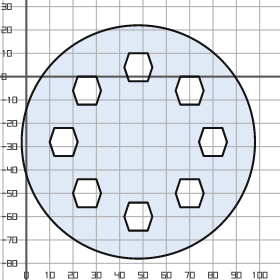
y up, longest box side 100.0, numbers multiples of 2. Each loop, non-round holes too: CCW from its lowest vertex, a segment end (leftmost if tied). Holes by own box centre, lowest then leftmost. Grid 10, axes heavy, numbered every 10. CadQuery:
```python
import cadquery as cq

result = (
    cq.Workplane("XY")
    .moveTo(48.0, -28.0)
    .circle(50.0)
    .moveTo(44.0, -66.0)
    .lineTo(52.0, -66.0)
    .lineTo(54.0, -60.0)
    .lineTo(52.0, -54.0)
    .lineTo(44.0, -54.0)
    .lineTo(42.0, -60.0)
    .close()
    .moveTo(22.0, -56.0)
    .lineTo(30.0, -56.0)
    .lineTo(32.0, -50.0)
    .lineTo(30.0, -44.0)
    .lineTo(22.0, -44.0)
    .lineTo(20.0, -50.0)
    .close()
    .moveTo(66.0, -56.0)
    .lineTo(74.0, -56.0)
    .lineTo(76.0, -50.0)
    .lineTo(74.0, -44.0)
    .lineTo(66.0, -44.0)
    .lineTo(64.0, -50.0)
    .close()
    .moveTo(12.0, -34.0)
    .lineTo(20.0, -34.0)
    .lineTo(22.0, -28.0)
    .lineTo(20.0, -22.0)
    .lineTo(12.0, -22.0)
    .lineTo(10.0, -28.0)
    .close()
    .moveTo(76.0, -34.0)
    .lineTo(84.0, -34.0)
    .lineTo(86.0, -28.0)
    .lineTo(84.0, -22.0)
    .lineTo(76.0, -22.0)
    .lineTo(74.0, -28.0)
    .close()
    .moveTo(22.0, -12.0)
    .lineTo(30.0, -12.0)
    .lineTo(32.0, -6.0)
    .lineTo(30.0, 0.0)
    .lineTo(22.0, 0.0)
    .lineTo(20.0, -6.0)
    .close()
    .moveTo(66.0, -12.0)
    .lineTo(74.0, -12.0)
    .lineTo(76.0, -6.0)
    .lineTo(74.0, 0.0)
    .lineTo(66.0, 0.0)
    .lineTo(64.0, -6.0)
    .close()
    .moveTo(44.0, -2.0)
    .lineTo(52.0, -2.0)
    .lineTo(54.0, 4.0)
    .lineTo(52.0, 10.0)
    .lineTo(44.0, 10.0)
    .lineTo(42.0, 4.0)
    .close()
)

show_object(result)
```